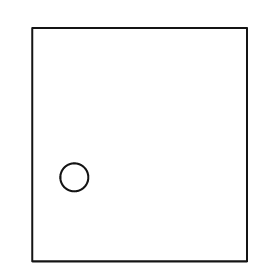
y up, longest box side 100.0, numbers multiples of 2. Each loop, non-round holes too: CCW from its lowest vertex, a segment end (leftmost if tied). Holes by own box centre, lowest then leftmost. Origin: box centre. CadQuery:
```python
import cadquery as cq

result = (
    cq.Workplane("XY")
    .moveTo(-46.0, -50.0)
    .lineTo(46.0, -50.0)
    .lineTo(46.0, 50.0)
    .lineTo(-46.0, 50.0)
    .close()
    .moveTo(-28.0, -14.0)
    .circle(6.0)
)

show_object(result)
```